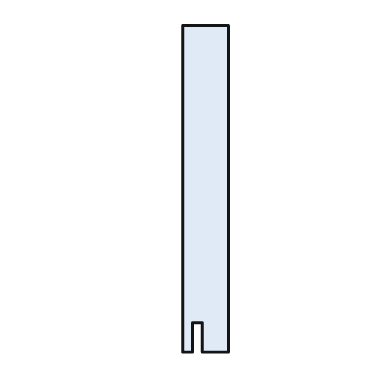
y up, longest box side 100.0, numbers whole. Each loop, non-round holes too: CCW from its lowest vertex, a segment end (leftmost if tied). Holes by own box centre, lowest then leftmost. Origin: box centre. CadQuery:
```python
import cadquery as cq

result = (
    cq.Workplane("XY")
    .moveTo(-7.0, -50.0)
    .lineTo(-4.0, -50.0)
    .lineTo(-4.0, -41.0)
    .lineTo(-1.0, -41.0)
    .lineTo(-1.0, -50.0)
    .lineTo(7.0, -50.0)
    .lineTo(7.0, 50.0)
    .lineTo(-7.0, 50.0)
    .close()
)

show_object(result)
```